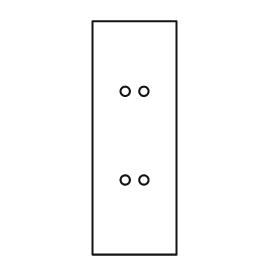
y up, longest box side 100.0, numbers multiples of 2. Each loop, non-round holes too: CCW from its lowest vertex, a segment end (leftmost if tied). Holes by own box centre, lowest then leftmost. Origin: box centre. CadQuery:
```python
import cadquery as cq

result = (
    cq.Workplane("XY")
    .moveTo(-18.0, -50.0)
    .lineTo(18.0, -50.0)
    .lineTo(18.0, 50.0)
    .lineTo(-18.0, 50.0)
    .close()
    .moveTo(-4.0, -18.0)
    .circle(2.0)
    .moveTo(4.0, -18.0)
    .circle(2.0)
    .moveTo(-4.0, 20.0)
    .circle(2.0)
    .moveTo(4.0, 20.0)
    .circle(2.0)
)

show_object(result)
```